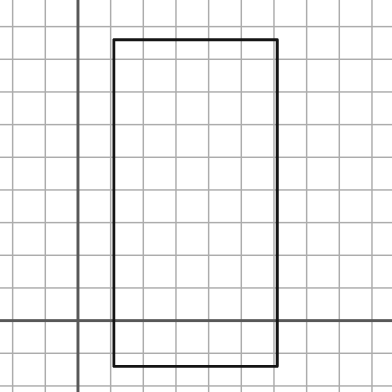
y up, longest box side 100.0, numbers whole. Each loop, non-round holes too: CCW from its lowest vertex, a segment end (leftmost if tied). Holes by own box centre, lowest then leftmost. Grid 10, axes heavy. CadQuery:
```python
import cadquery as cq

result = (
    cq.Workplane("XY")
    .moveTo(11.0, -14.0)
    .lineTo(61.0, -14.0)
    .lineTo(61.0, 86.0)
    .lineTo(11.0, 86.0)
    .close()
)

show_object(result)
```